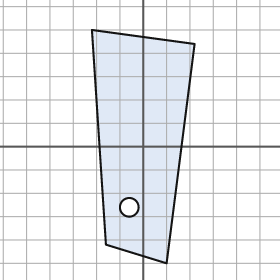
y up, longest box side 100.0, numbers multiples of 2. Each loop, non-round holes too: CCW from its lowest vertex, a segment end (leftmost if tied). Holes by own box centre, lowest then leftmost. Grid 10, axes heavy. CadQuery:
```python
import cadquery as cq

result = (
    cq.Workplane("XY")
    .moveTo(10.0, -50.0)
    .lineTo(22.0, 44.0)
    .lineTo(-22.0, 50.0)
    .lineTo(-16.0, -42.0)
    .close()
    .moveTo(-6.0, -26.0)
    .circle(4.0)
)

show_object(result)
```